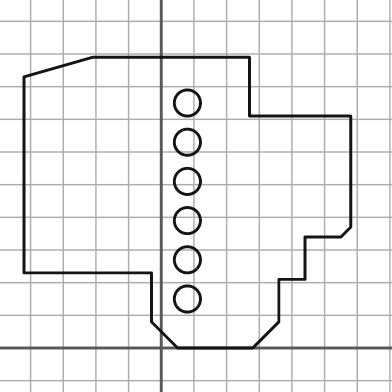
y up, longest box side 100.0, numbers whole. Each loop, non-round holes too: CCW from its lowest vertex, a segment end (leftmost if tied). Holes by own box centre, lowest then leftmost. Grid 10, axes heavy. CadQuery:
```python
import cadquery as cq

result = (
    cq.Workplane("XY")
    .moveTo(5.0, 0.0)
    .lineTo(28.0, 0.0)
    .lineTo(36.0, 8.0)
    .lineTo(36.0, 21.0)
    .lineTo(44.0, 21.0)
    .lineTo(44.0, 34.0)
    .lineTo(55.0, 34.0)
    .lineTo(58.0, 37.0)
    .lineTo(58.0, 71.0)
    .lineTo(27.0, 71.0)
    .lineTo(27.0, 89.0)
    .lineTo(-21.0, 89.0)
    .lineTo(-42.0, 83.0)
    .lineTo(-42.0, 23.0)
    .lineTo(-3.0, 23.0)
    .lineTo(-3.0, 8.0)
    .close()
    .moveTo(8.0, 15.0)
    .circle(4.0)
    .moveTo(8.0, 27.0)
    .circle(4.0)
    .moveTo(8.0, 39.0)
    .circle(4.0)
    .moveTo(8.0, 51.0)
    .circle(4.0)
    .moveTo(8.0, 63.0)
    .circle(4.0)
    .moveTo(8.0, 75.0)
    .circle(4.0)
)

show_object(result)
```